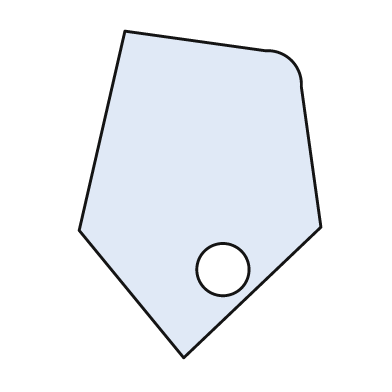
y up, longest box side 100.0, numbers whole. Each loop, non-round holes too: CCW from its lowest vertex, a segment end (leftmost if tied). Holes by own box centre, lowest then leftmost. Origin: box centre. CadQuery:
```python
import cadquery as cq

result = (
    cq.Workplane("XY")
    .moveTo(-5.0, -50.0)
    .lineTo(37.0, -10.0)
    .lineTo(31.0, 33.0)
    .threePointArc((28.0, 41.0), (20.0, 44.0))
    .lineTo(-23.0, 50.0)
    .lineTo(-37.0, -11.0)
    .close()
    .moveTo(7.0, -23.0)
    .circle(8.0)
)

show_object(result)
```